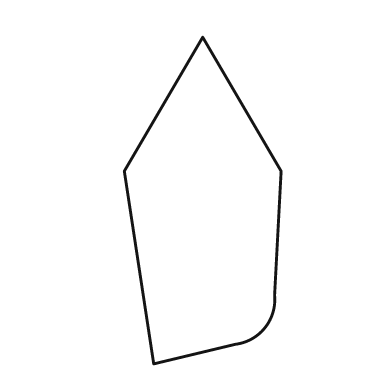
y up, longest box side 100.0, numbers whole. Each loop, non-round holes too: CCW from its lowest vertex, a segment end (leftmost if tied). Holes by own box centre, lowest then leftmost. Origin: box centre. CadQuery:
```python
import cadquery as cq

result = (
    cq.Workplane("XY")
    .moveTo(-15.0, -50.0)
    .lineTo(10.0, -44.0)
    .threePointArc((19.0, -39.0), (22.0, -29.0))
    .lineTo(24.0, 9.0)
    .lineTo(0.0, 50.0)
    .lineTo(-24.0, 9.0)
    .close()
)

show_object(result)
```